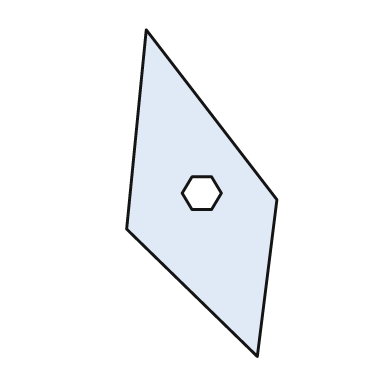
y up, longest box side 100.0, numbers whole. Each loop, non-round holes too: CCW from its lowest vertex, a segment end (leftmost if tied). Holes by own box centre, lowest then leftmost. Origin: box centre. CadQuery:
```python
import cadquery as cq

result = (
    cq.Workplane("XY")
    .moveTo(17.0, -50.0)
    .lineTo(23.0, -2.0)
    .lineTo(-17.0, 50.0)
    .lineTo(-23.0, -11.0)
    .close()
    .moveTo(-3.0, -5.0)
    .lineTo(3.0, -5.0)
    .lineTo(6.0, 0.0)
    .lineTo(3.0, 5.0)
    .lineTo(-3.0, 5.0)
    .lineTo(-6.0, 0.0)
    .close()
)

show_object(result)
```